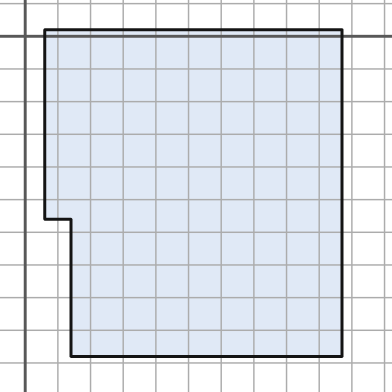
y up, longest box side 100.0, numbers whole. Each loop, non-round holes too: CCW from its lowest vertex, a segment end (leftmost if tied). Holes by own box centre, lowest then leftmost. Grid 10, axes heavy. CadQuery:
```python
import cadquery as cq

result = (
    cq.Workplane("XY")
    .moveTo(14.0, -98.0)
    .lineTo(97.0, -98.0)
    .lineTo(97.0, 2.0)
    .lineTo(6.0, 2.0)
    .lineTo(6.0, -56.0)
    .lineTo(14.0, -56.0)
    .close()
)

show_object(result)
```